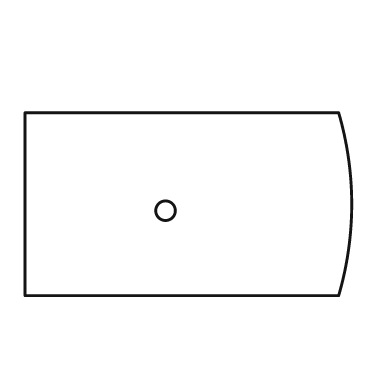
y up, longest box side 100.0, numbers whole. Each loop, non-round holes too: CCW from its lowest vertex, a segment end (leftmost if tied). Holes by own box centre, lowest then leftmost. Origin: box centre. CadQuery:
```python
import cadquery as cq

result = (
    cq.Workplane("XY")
    .moveTo(-50.0, -28.0)
    .lineTo(46.0, -28.0)
    .threePointArc((50.0, 0.0), (46.0, 28.0))
    .lineTo(-50.0, 28.0)
    .close()
    .moveTo(-7.0, -2.0)
    .circle(3.0)
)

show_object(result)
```